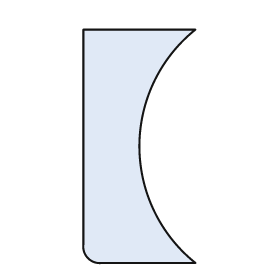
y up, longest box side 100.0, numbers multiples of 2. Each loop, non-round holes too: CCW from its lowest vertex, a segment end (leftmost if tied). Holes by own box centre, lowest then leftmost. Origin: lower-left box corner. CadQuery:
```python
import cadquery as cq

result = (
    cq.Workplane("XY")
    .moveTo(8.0, 0.0)
    .lineTo(48.0, 0.0)
    .threePointArc((24.0, 50.0), (48.0, 100.0))
    .lineTo(0.0, 100.0)
    .lineTo(0.0, 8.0)
    .threePointArc((2.0, 2.0), (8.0, 0.0))
    .close()
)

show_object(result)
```